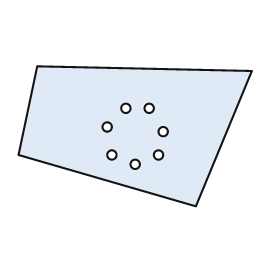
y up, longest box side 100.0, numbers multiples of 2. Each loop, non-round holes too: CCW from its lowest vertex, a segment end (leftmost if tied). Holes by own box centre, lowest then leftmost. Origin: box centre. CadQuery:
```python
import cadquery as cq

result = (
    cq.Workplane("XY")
    .moveTo(26.0, -30.0)
    .lineTo(50.0, 28.0)
    .lineTo(-42.0, 30.0)
    .lineTo(-50.0, -8.0)
    .close()
    .moveTo(0.0, -12.0)
    .circle(2.0)
    .moveTo(-10.0, -8.0)
    .circle(2.0)
    .moveTo(10.0, -8.0)
    .circle(2.0)
    .moveTo(12.0, 2.0)
    .circle(2.0)
    .moveTo(-12.0, 4.0)
    .circle(2.0)
    .moveTo(-4.0, 12.0)
    .circle(2.0)
    .moveTo(6.0, 12.0)
    .circle(2.0)
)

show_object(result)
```